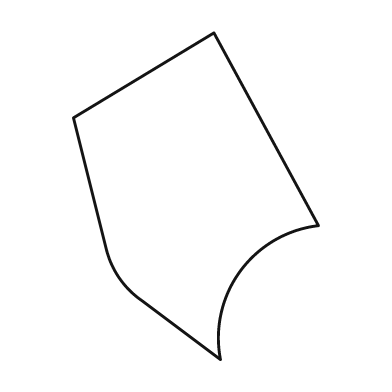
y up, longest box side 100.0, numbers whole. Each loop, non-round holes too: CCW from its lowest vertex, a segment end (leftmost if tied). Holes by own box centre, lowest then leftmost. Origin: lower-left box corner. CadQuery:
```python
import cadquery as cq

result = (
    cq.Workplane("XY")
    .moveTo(45.0, 0.0)
    .threePointArc((51.0, 27.0), (75.0, 41.0))
    .lineTo(43.0, 100.0)
    .lineTo(0.0, 74.0)
    .lineTo(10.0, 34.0)
    .threePointArc((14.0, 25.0), (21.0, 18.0))
    .close()
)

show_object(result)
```